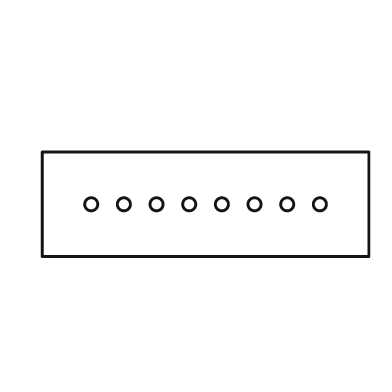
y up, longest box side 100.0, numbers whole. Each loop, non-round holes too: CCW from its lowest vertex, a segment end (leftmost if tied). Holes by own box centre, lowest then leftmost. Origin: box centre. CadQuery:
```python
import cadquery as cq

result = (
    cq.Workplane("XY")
    .moveTo(-50.0, -16.0)
    .lineTo(50.0, -16.0)
    .lineTo(50.0, 16.0)
    .lineTo(-50.0, 16.0)
    .close()
    .moveTo(-35.0, 0.0)
    .circle(2.0)
    .moveTo(-25.0, 0.0)
    .circle(2.0)
    .moveTo(-15.0, 0.0)
    .circle(2.0)
    .moveTo(-5.0, 0.0)
    .circle(2.0)
    .moveTo(5.0, 0.0)
    .circle(2.0)
    .moveTo(15.0, 0.0)
    .circle(2.0)
    .moveTo(25.0, 0.0)
    .circle(2.0)
    .moveTo(35.0, 0.0)
    .circle(2.0)
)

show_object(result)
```